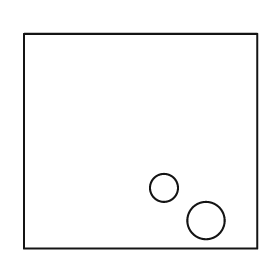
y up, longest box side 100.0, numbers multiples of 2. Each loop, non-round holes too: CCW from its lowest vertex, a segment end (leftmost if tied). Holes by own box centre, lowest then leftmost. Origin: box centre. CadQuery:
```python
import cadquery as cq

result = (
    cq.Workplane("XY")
    .moveTo(-50.0, -46.0)
    .lineTo(50.0, -46.0)
    .lineTo(50.0, 46.0)
    .lineTo(-50.0, 46.0)
    .close()
    .moveTo(28.0, -34.0)
    .circle(8.0)
    .moveTo(10.0, -20.0)
    .circle(6.0)
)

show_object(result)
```